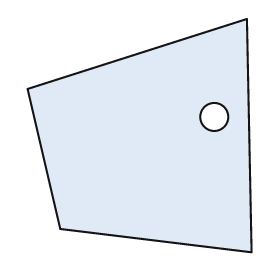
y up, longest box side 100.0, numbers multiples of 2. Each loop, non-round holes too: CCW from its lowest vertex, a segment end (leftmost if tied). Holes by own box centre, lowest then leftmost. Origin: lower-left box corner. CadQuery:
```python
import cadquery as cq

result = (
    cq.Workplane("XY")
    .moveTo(96.0, 0.0)
    .lineTo(94.0, 100.0)
    .lineTo(0.0, 70.0)
    .lineTo(14.0, 10.0)
    .close()
    .moveTo(80.0, 58.0)
    .circle(6.0)
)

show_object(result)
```